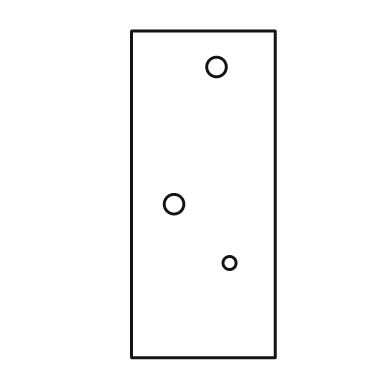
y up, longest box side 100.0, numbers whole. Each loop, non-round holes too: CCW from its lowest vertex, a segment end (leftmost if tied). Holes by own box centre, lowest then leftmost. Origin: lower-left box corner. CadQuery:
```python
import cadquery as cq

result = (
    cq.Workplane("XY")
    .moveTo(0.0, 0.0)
    .lineTo(44.0, 0.0)
    .lineTo(44.0, 100.0)
    .lineTo(0.0, 100.0)
    .close()
    .moveTo(30.0, 29.0)
    .circle(2.0)
    .moveTo(13.0, 47.0)
    .circle(3.0)
    .moveTo(26.0, 89.0)
    .circle(3.0)
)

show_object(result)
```